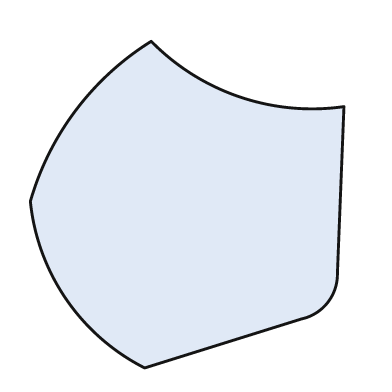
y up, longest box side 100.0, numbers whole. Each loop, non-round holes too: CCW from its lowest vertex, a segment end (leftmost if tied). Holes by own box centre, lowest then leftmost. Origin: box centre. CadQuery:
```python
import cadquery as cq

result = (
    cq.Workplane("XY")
    .moveTo(-13.0, -50.0)
    .lineTo(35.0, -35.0)
    .threePointArc((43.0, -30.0), (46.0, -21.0))
    .lineTo(48.0, 30.0)
    .threePointArc((16.0, 33.0), (-11.0, 50.0))
    .threePointArc((-34.0, 29.0), (-48.0, 1.0))
    .threePointArc((-37.0, -29.0), (-13.0, -50.0))
    .close()
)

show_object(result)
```